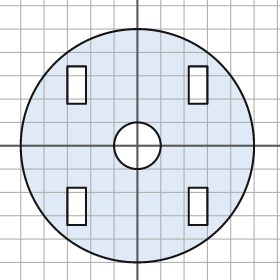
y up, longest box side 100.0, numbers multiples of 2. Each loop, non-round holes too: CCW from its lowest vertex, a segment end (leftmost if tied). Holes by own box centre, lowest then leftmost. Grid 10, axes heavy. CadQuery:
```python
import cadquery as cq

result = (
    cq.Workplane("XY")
    .moveTo(0.0, 0.0)
    .circle(50.0)
    .moveTo(-30.0, -34.0)
    .lineTo(-22.0, -34.0)
    .lineTo(-22.0, -18.0)
    .lineTo(-30.0, -18.0)
    .close()
    .moveTo(22.0, -34.0)
    .lineTo(30.0, -34.0)
    .lineTo(30.0, -18.0)
    .lineTo(22.0, -18.0)
    .close()
    .moveTo(0.0, 0.0)
    .circle(10.0)
    .moveTo(-30.0, 18.0)
    .lineTo(-22.0, 18.0)
    .lineTo(-22.0, 34.0)
    .lineTo(-30.0, 34.0)
    .close()
    .moveTo(22.0, 18.0)
    .lineTo(30.0, 18.0)
    .lineTo(30.0, 34.0)
    .lineTo(22.0, 34.0)
    .close()
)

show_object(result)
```